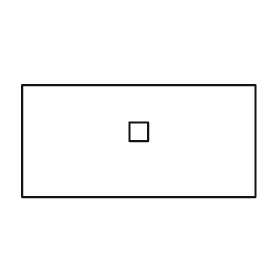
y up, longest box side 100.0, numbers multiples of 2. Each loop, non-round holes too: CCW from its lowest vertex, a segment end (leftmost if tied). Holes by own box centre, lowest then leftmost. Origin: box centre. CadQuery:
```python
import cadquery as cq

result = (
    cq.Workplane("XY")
    .moveTo(-50.0, -24.0)
    .lineTo(50.0, -24.0)
    .lineTo(50.0, 24.0)
    .lineTo(-50.0, 24.0)
    .close()
    .moveTo(-4.0, 0.0)
    .lineTo(4.0, 0.0)
    .lineTo(4.0, 8.0)
    .lineTo(-4.0, 8.0)
    .close()
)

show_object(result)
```